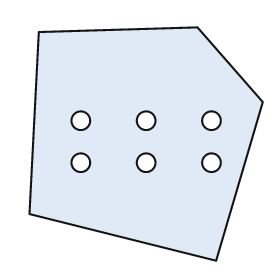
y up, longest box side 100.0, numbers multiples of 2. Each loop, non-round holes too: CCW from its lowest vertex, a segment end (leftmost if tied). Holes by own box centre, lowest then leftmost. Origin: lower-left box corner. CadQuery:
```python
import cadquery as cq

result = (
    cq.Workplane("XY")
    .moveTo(80.0, 0.0)
    .lineTo(100.0, 68.0)
    .lineTo(72.0, 100.0)
    .lineTo(4.0, 98.0)
    .lineTo(0.0, 20.0)
    .close()
    .moveTo(22.0, 42.0)
    .circle(4.0)
    .moveTo(50.0, 42.0)
    .circle(4.0)
    .moveTo(78.0, 42.0)
    .circle(4.0)
    .moveTo(22.0, 60.0)
    .circle(4.0)
    .moveTo(50.0, 60.0)
    .circle(4.0)
    .moveTo(78.0, 60.0)
    .circle(4.0)
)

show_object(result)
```